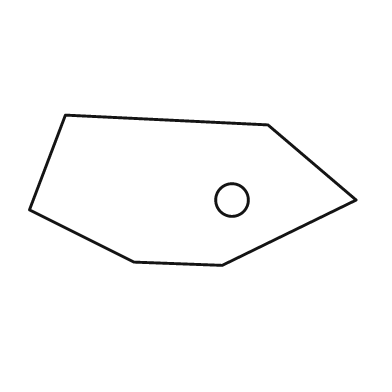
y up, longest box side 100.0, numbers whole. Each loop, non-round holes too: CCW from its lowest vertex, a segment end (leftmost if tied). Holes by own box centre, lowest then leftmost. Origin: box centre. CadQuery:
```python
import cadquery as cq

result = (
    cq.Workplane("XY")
    .moveTo(9.0, -23.0)
    .lineTo(50.0, -3.0)
    .lineTo(23.0, 20.0)
    .lineTo(-39.0, 23.0)
    .lineTo(-50.0, -6.0)
    .lineTo(-18.0, -22.0)
    .close()
    .moveTo(12.0, -3.0)
    .circle(5.0)
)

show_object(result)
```